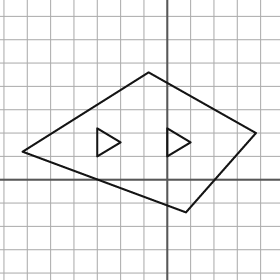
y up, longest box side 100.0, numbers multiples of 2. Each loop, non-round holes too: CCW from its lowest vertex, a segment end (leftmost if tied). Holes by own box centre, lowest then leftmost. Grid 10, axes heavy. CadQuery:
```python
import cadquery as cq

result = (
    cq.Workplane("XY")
    .moveTo(8.0, -14.0)
    .lineTo(38.0, 20.0)
    .lineTo(-8.0, 46.0)
    .lineTo(-62.0, 12.0)
    .close()
    .moveTo(-30.0, 10.0)
    .lineTo(-20.0, 16.0)
    .lineTo(-30.0, 22.0)
    .close()
    .moveTo(0.0, 10.0)
    .lineTo(10.0, 16.0)
    .lineTo(0.0, 22.0)
    .close()
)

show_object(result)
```